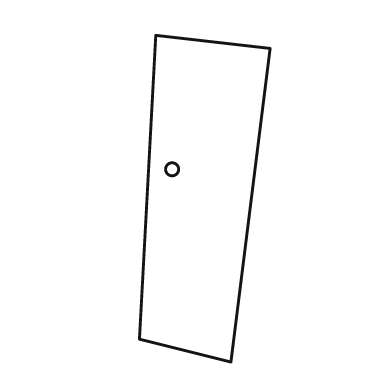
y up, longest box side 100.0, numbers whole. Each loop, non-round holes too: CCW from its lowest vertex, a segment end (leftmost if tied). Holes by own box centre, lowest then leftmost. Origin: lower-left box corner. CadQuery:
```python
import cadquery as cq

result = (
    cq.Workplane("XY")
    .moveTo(28.0, 0.0)
    .lineTo(40.0, 96.0)
    .lineTo(5.0, 100.0)
    .lineTo(0.0, 7.0)
    .close()
    .moveTo(10.0, 59.0)
    .circle(2.0)
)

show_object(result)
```